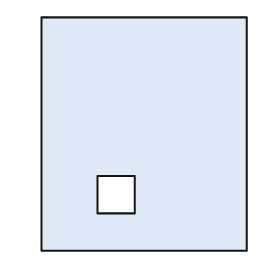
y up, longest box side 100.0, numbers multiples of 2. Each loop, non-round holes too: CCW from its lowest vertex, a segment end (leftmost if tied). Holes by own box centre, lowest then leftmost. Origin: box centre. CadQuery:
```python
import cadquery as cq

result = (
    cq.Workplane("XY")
    .moveTo(-44.0, -50.0)
    .lineTo(44.0, -50.0)
    .lineTo(44.0, 50.0)
    .lineTo(-44.0, 50.0)
    .close()
    .moveTo(-20.0, -34.0)
    .lineTo(-4.0, -34.0)
    .lineTo(-4.0, -18.0)
    .lineTo(-20.0, -18.0)
    .close()
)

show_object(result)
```